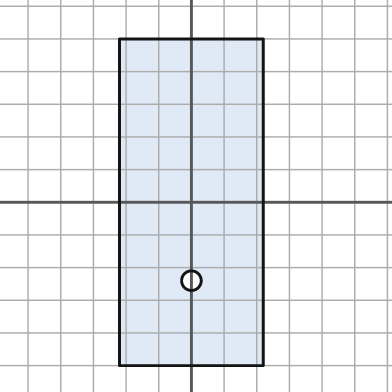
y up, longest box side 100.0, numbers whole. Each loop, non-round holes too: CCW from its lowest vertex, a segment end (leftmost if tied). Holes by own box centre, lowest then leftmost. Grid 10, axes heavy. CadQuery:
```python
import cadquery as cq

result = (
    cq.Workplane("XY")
    .moveTo(-22.0, -50.0)
    .lineTo(22.0, -50.0)
    .lineTo(22.0, 50.0)
    .lineTo(-22.0, 50.0)
    .close()
    .moveTo(0.0, -24.0)
    .circle(3.0)
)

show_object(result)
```